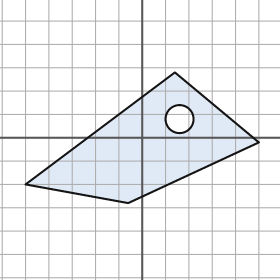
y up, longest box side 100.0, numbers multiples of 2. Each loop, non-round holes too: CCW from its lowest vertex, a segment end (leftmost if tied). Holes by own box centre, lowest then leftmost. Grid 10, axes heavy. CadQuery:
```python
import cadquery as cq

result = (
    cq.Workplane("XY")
    .moveTo(-6.0, -28.0)
    .lineTo(50.0, -2.0)
    .lineTo(14.0, 28.0)
    .lineTo(-50.0, -20.0)
    .close()
    .moveTo(16.0, 8.0)
    .circle(6.0)
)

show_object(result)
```